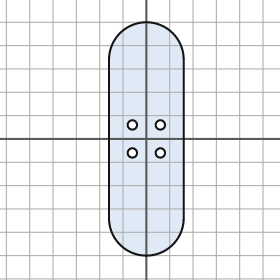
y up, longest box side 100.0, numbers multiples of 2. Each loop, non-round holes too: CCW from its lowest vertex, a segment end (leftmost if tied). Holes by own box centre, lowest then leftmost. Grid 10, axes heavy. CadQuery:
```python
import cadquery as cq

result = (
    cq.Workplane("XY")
    .moveTo(-16.0, -34.0)
    .threePointArc((0.0, -50.0), (16.0, -34.0))
    .lineTo(16.0, 34.0)
    .threePointArc((0.0, 50.0), (-16.0, 34.0))
    .close()
    .moveTo(-6.0, -6.0)
    .circle(2.0)
    .moveTo(6.0, -6.0)
    .circle(2.0)
    .moveTo(-6.0, 6.0)
    .circle(2.0)
    .moveTo(6.0, 6.0)
    .circle(2.0)
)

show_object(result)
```